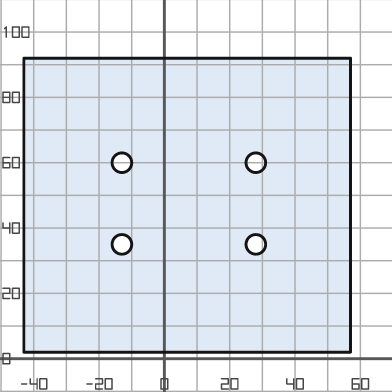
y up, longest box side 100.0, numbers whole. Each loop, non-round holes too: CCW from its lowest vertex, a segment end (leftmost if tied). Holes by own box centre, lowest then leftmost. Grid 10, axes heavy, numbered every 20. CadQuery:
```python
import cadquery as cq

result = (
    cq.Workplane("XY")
    .moveTo(-43.0, 2.0)
    .lineTo(57.0, 2.0)
    .lineTo(57.0, 92.0)
    .lineTo(-43.0, 92.0)
    .close()
    .moveTo(-13.0, 35.0)
    .circle(3.0)
    .moveTo(28.0, 35.0)
    .circle(3.0)
    .moveTo(-13.0, 60.0)
    .circle(3.0)
    .moveTo(28.0, 60.0)
    .circle(3.0)
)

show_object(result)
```